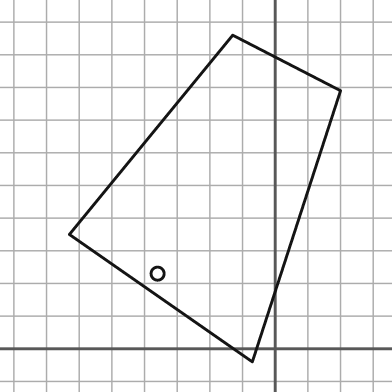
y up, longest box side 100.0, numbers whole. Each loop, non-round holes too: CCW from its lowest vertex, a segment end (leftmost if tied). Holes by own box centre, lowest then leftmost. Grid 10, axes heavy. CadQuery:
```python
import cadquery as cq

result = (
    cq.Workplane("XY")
    .moveTo(-7.0, -4.0)
    .lineTo(20.0, 79.0)
    .lineTo(-13.0, 96.0)
    .lineTo(-63.0, 35.0)
    .close()
    .moveTo(-36.0, 23.0)
    .circle(2.0)
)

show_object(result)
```